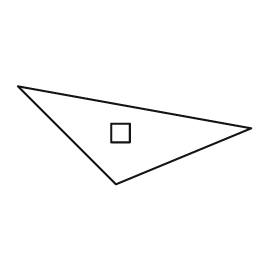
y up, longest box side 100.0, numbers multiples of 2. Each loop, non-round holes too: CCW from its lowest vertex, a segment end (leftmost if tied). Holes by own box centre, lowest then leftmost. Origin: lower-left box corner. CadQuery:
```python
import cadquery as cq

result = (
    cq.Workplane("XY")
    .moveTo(42.0, 0.0)
    .lineTo(100.0, 24.0)
    .lineTo(0.0, 42.0)
    .close()
    .moveTo(40.0, 18.0)
    .lineTo(48.0, 18.0)
    .lineTo(48.0, 26.0)
    .lineTo(40.0, 26.0)
    .close()
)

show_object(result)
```